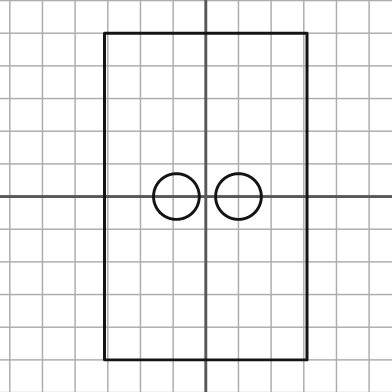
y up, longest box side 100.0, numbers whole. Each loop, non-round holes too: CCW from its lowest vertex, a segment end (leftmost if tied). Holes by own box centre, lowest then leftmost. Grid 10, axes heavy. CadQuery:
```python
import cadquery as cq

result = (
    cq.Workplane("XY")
    .moveTo(-31.0, -50.0)
    .lineTo(31.0, -50.0)
    .lineTo(31.0, 50.0)
    .lineTo(-31.0, 50.0)
    .close()
    .moveTo(-9.0, 0.0)
    .circle(7.0)
    .moveTo(10.0, 0.0)
    .circle(7.0)
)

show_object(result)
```